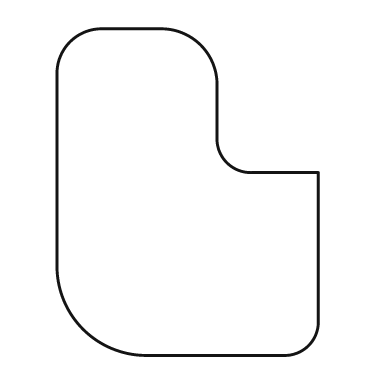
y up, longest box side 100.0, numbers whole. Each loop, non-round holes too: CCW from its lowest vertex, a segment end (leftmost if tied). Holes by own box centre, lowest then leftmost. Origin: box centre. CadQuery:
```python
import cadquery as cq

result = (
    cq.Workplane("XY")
    .moveTo(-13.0, -50.0)
    .lineTo(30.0, -50.0)
    .threePointArc((37.0, -47.0), (40.0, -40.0))
    .lineTo(40.0, 6.0)
    .lineTo(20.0, 6.0)
    .threePointArc((12.0, 9.0), (9.0, 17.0))
    .lineTo(9.0, 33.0)
    .threePointArc((4.0, 45.0), (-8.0, 50.0))
    .lineTo(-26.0, 50.0)
    .threePointArc((-36.0, 46.0), (-40.0, 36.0))
    .lineTo(-40.0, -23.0)
    .threePointArc((-32.0, -42.0), (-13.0, -50.0))
    .close()
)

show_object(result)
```